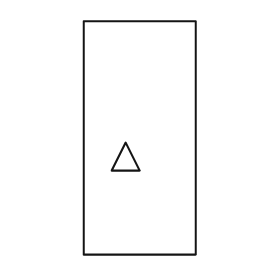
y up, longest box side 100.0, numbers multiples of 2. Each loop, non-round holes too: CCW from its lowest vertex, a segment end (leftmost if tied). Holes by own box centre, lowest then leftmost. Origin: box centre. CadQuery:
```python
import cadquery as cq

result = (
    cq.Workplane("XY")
    .moveTo(-24.0, -50.0)
    .lineTo(24.0, -50.0)
    .lineTo(24.0, 50.0)
    .lineTo(-24.0, 50.0)
    .close()
    .moveTo(-12.0, -14.0)
    .lineTo(0.0, -14.0)
    .lineTo(-6.0, -2.0)
    .close()
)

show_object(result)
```